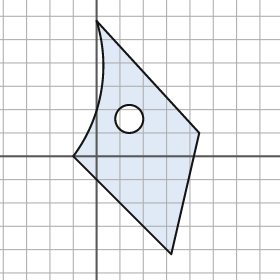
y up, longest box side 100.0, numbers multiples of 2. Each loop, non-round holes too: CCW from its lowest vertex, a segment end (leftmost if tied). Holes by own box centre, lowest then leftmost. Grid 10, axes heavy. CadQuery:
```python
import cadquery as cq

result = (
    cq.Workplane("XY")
    .moveTo(32.0, -42.0)
    .lineTo(44.0, 10.0)
    .lineTo(0.0, 58.0)
    .threePointArc((2.0, 28.0), (-10.0, 0.0))
    .close()
    .moveTo(14.0, 16.0)
    .circle(6.0)
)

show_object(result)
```